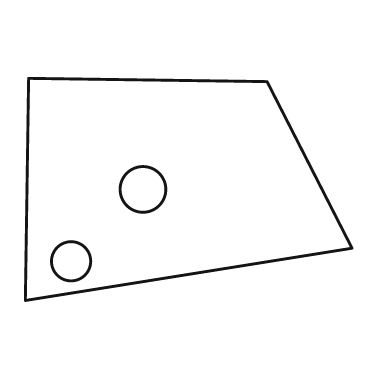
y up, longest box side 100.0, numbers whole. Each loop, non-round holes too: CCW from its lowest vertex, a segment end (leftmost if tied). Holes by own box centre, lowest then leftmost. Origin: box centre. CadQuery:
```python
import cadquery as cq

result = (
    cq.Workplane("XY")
    .moveTo(-50.0, -34.0)
    .lineTo(50.0, -18.0)
    .lineTo(24.0, 33.0)
    .lineTo(-49.0, 34.0)
    .close()
    .moveTo(-36.0, -22.0)
    .circle(6.0)
    .moveTo(-14.0, 0.0)
    .circle(7.0)
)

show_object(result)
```